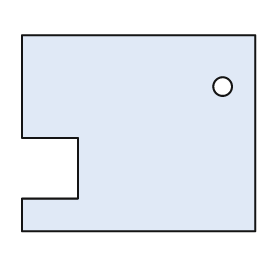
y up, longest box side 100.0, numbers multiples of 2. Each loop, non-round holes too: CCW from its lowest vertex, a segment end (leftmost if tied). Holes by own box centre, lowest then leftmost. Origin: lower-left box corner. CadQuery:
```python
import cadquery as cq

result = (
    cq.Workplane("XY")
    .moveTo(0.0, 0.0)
    .lineTo(100.0, 0.0)
    .lineTo(100.0, 84.0)
    .lineTo(0.0, 84.0)
    .lineTo(0.0, 40.0)
    .lineTo(24.0, 40.0)
    .lineTo(24.0, 14.0)
    .lineTo(0.0, 14.0)
    .close()
    .moveTo(86.0, 62.0)
    .circle(4.0)
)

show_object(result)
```